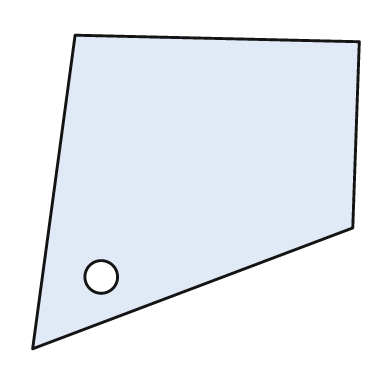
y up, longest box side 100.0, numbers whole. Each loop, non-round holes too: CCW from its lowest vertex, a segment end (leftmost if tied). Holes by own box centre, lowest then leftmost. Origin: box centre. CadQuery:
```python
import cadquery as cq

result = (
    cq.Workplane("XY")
    .moveTo(-50.0, -48.0)
    .lineTo(48.0, -11.0)
    .lineTo(50.0, 46.0)
    .lineTo(-37.0, 48.0)
    .close()
    .moveTo(-29.0, -26.0)
    .circle(5.0)
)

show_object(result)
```